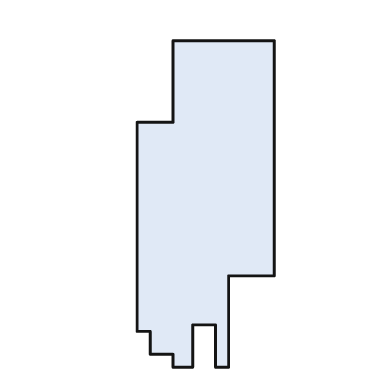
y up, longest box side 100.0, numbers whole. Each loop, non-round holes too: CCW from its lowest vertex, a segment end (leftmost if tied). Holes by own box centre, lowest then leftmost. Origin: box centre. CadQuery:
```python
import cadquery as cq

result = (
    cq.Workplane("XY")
    .moveTo(-10.0, -50.0)
    .lineTo(-4.0, -50.0)
    .lineTo(-4.0, -37.0)
    .lineTo(3.0, -37.0)
    .lineTo(3.0, -50.0)
    .lineTo(7.0, -50.0)
    .lineTo(7.0, -22.0)
    .lineTo(21.0, -22.0)
    .lineTo(21.0, 50.0)
    .lineTo(-10.0, 50.0)
    .lineTo(-10.0, 25.0)
    .lineTo(-21.0, 25.0)
    .lineTo(-21.0, -39.0)
    .lineTo(-17.0, -39.0)
    .lineTo(-17.0, -46.0)
    .lineTo(-10.0, -46.0)
    .close()
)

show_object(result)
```